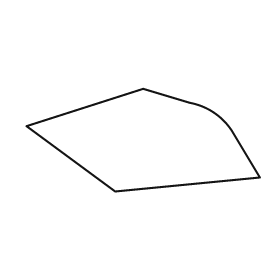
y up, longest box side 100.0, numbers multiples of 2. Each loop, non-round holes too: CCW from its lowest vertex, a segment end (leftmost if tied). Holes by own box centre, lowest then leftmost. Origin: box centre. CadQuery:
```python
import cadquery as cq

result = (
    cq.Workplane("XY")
    .moveTo(-12.0, -22.0)
    .lineTo(50.0, -16.0)
    .lineTo(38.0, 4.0)
    .threePointArc((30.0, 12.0), (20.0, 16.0))
    .lineTo(0.0, 22.0)
    .lineTo(-50.0, 6.0)
    .close()
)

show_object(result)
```